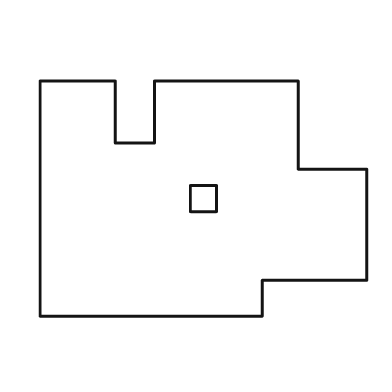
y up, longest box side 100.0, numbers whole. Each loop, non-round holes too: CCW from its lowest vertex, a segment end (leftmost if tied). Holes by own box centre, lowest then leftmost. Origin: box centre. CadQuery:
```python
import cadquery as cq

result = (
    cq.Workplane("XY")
    .moveTo(-50.0, -36.0)
    .lineTo(18.0, -36.0)
    .lineTo(18.0, -25.0)
    .lineTo(50.0, -25.0)
    .lineTo(50.0, 9.0)
    .lineTo(29.0, 9.0)
    .lineTo(29.0, 36.0)
    .lineTo(-15.0, 36.0)
    .lineTo(-15.0, 17.0)
    .lineTo(-27.0, 17.0)
    .lineTo(-27.0, 36.0)
    .lineTo(-50.0, 36.0)
    .close()
    .moveTo(-4.0, -4.0)
    .lineTo(4.0, -4.0)
    .lineTo(4.0, 4.0)
    .lineTo(-4.0, 4.0)
    .close()
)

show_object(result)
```